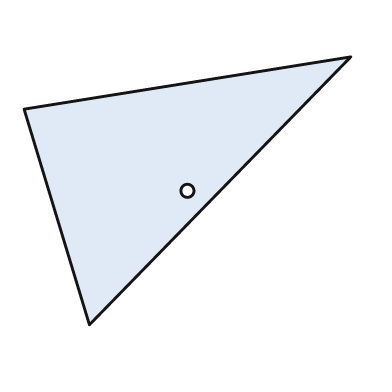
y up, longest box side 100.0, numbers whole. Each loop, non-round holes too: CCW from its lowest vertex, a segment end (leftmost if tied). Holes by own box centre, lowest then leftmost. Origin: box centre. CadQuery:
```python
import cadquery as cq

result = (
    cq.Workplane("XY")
    .moveTo(-30.0, -41.0)
    .lineTo(50.0, 41.0)
    .lineTo(-50.0, 25.0)
    .close()
    .moveTo(0.0, 0.0)
    .circle(2.0)
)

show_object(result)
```